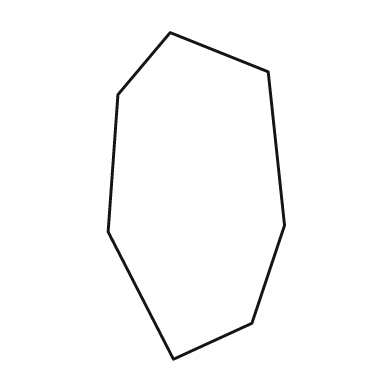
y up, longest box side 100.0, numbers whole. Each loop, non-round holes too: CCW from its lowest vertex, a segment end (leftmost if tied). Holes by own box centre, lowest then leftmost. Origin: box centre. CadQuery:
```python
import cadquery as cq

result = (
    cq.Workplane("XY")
    .moveTo(-7.0, -50.0)
    .lineTo(17.0, -39.0)
    .lineTo(27.0, -9.0)
    .lineTo(22.0, 38.0)
    .lineTo(-8.0, 50.0)
    .lineTo(-24.0, 31.0)
    .lineTo(-27.0, -11.0)
    .close()
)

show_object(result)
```